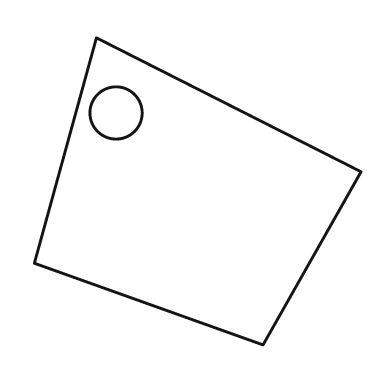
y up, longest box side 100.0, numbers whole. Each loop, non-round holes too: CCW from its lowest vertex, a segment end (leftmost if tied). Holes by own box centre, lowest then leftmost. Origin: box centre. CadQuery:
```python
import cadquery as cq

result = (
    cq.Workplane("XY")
    .moveTo(20.0, -47.0)
    .lineTo(50.0, 6.0)
    .lineTo(-31.0, 47.0)
    .lineTo(-50.0, -22.0)
    .close()
    .moveTo(-25.0, 24.0)
    .circle(8.0)
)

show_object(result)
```